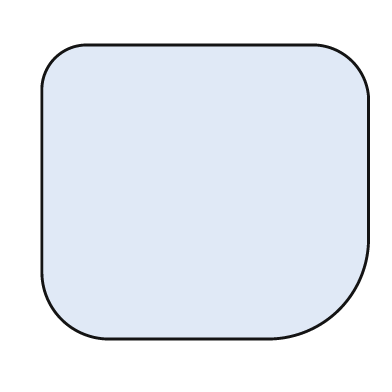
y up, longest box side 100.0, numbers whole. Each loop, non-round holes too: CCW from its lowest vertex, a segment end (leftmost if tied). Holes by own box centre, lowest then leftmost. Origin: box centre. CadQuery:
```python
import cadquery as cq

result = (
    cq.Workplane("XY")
    .moveTo(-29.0, -45.0)
    .lineTo(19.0, -45.0)
    .threePointArc((41.0, -36.0), (50.0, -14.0))
    .lineTo(50.0, 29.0)
    .threePointArc((45.0, 40.0), (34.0, 45.0))
    .lineTo(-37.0, 45.0)
    .threePointArc((-46.0, 41.0), (-50.0, 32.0))
    .lineTo(-50.0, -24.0)
    .threePointArc((-44.0, -39.0), (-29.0, -45.0))
    .close()
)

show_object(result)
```